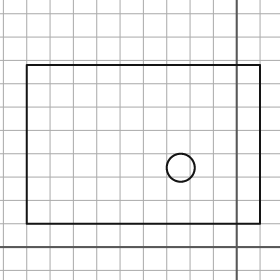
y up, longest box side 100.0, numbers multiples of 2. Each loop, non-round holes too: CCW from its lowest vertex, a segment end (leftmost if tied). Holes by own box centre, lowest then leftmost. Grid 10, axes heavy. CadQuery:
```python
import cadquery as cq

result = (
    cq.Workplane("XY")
    .moveTo(-90.0, 10.0)
    .lineTo(10.0, 10.0)
    .lineTo(10.0, 78.0)
    .lineTo(-90.0, 78.0)
    .close()
    .moveTo(-24.0, 34.0)
    .circle(6.0)
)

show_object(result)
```